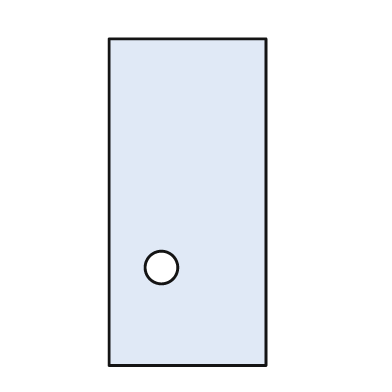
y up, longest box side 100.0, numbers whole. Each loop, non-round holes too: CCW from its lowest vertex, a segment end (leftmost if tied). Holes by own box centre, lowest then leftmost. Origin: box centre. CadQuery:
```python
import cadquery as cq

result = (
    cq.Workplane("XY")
    .moveTo(-24.0, -50.0)
    .lineTo(24.0, -50.0)
    .lineTo(24.0, 50.0)
    .lineTo(-24.0, 50.0)
    .close()
    .moveTo(-8.0, -20.0)
    .circle(5.0)
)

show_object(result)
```